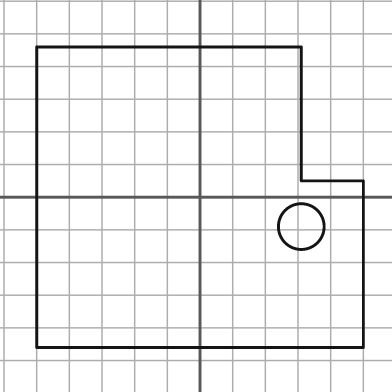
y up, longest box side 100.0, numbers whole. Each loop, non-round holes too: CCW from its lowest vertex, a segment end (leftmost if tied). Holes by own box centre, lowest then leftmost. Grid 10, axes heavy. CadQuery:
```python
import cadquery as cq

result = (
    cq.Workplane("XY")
    .moveTo(-50.0, -46.0)
    .lineTo(50.0, -46.0)
    .lineTo(50.0, 5.0)
    .lineTo(31.0, 5.0)
    .lineTo(31.0, 46.0)
    .lineTo(-50.0, 46.0)
    .close()
    .moveTo(31.0, -9.0)
    .circle(7.0)
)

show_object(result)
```